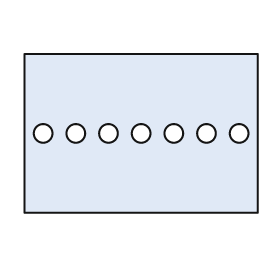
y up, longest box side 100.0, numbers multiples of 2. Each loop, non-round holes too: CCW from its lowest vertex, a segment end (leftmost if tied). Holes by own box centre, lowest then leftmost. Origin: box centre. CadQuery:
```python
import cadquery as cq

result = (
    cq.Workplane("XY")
    .moveTo(-50.0, -34.0)
    .lineTo(50.0, -34.0)
    .lineTo(50.0, 34.0)
    .lineTo(-50.0, 34.0)
    .close()
    .moveTo(-42.0, 0.0)
    .circle(4.0)
    .moveTo(-28.0, 0.0)
    .circle(4.0)
    .moveTo(-14.0, 0.0)
    .circle(4.0)
    .moveTo(0.0, 0.0)
    .circle(4.0)
    .moveTo(14.0, 0.0)
    .circle(4.0)
    .moveTo(28.0, 0.0)
    .circle(4.0)
    .moveTo(42.0, 0.0)
    .circle(4.0)
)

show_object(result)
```